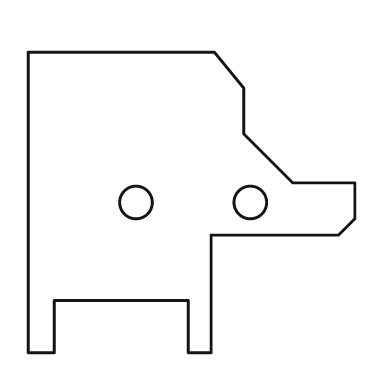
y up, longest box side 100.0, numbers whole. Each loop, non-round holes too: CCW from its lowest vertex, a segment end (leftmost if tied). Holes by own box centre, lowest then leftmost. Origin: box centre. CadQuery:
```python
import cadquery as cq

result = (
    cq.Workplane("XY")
    .moveTo(-50.0, -46.0)
    .lineTo(-42.0, -46.0)
    .lineTo(-42.0, -30.0)
    .lineTo(-1.0, -30.0)
    .lineTo(-1.0, -46.0)
    .lineTo(6.0, -46.0)
    .lineTo(6.0, -10.0)
    .lineTo(45.0, -10.0)
    .lineTo(50.0, -5.0)
    .lineTo(50.0, 6.0)
    .lineTo(31.0, 6.0)
    .lineTo(16.0, 21.0)
    .lineTo(16.0, 35.0)
    .lineTo(7.0, 46.0)
    .lineTo(-50.0, 46.0)
    .close()
    .moveTo(-17.0, 0.0)
    .circle(5.0)
    .moveTo(18.0, 0.0)
    .circle(5.0)
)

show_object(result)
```